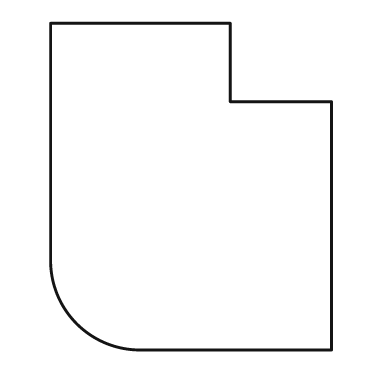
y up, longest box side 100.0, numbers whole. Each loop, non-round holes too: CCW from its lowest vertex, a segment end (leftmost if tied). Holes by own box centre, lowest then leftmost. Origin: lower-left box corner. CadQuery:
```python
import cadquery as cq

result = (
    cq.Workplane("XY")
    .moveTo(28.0, 0.0)
    .lineTo(86.0, 0.0)
    .lineTo(86.0, 76.0)
    .lineTo(55.0, 76.0)
    .lineTo(55.0, 100.0)
    .lineTo(0.0, 100.0)
    .lineTo(0.0, 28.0)
    .threePointArc((8.0, 8.0), (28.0, 0.0))
    .close()
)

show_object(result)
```